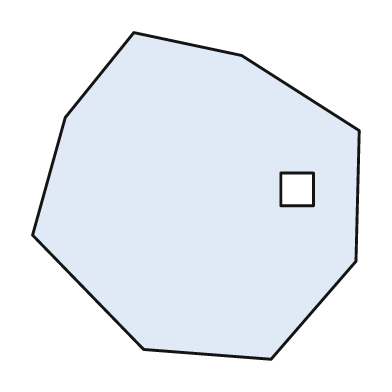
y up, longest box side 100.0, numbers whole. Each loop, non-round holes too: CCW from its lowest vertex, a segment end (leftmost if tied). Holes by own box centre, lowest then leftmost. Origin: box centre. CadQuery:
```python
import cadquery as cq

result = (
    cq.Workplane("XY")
    .moveTo(23.0, -50.0)
    .lineTo(49.0, -20.0)
    .lineTo(50.0, 20.0)
    .lineTo(14.0, 43.0)
    .lineTo(-19.0, 50.0)
    .lineTo(-40.0, 24.0)
    .lineTo(-50.0, -12.0)
    .lineTo(-16.0, -47.0)
    .close()
    .moveTo(26.0, -3.0)
    .lineTo(36.0, -3.0)
    .lineTo(36.0, 7.0)
    .lineTo(26.0, 7.0)
    .close()
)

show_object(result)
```